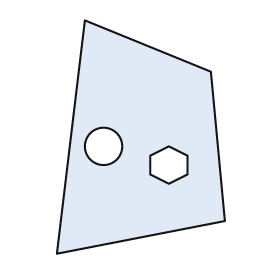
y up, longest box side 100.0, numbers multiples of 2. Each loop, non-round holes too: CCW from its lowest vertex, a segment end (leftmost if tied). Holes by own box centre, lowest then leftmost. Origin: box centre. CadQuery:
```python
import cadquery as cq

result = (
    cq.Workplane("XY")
    .moveTo(-36.0, -50.0)
    .lineTo(36.0, -36.0)
    .lineTo(30.0, 28.0)
    .lineTo(-24.0, 50.0)
    .close()
    .moveTo(12.0, -20.0)
    .lineTo(20.0, -16.0)
    .lineTo(20.0, -8.0)
    .lineTo(12.0, -4.0)
    .lineTo(4.0, -8.0)
    .lineTo(4.0, -16.0)
    .close()
    .moveTo(-16.0, -4.0)
    .circle(8.0)
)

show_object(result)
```